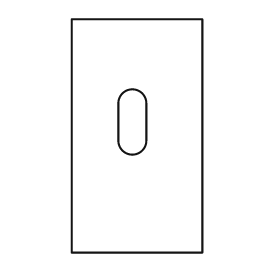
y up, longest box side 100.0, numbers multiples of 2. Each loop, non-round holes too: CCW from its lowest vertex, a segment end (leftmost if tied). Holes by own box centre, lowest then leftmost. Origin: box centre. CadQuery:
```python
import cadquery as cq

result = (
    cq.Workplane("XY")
    .moveTo(-28.0, -50.0)
    .lineTo(28.0, -50.0)
    .lineTo(28.0, 50.0)
    .lineTo(-28.0, 50.0)
    .close()
    .moveTo(-8.0, -2.0)
    .threePointArc((-2.0, -8.0), (4.0, -2.0))
    .lineTo(4.0, 14.0)
    .threePointArc((-2.0, 20.0), (-8.0, 14.0))
    .close()
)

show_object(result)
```